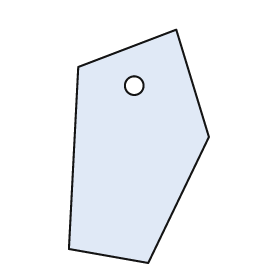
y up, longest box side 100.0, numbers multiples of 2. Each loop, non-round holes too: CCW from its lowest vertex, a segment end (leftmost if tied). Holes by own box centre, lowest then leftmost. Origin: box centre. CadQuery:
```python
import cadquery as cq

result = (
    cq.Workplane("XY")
    .moveTo(4.0, -50.0)
    .lineTo(30.0, 4.0)
    .lineTo(16.0, 50.0)
    .lineTo(-26.0, 34.0)
    .lineTo(-30.0, -44.0)
    .close()
    .moveTo(-2.0, 26.0)
    .circle(4.0)
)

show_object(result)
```